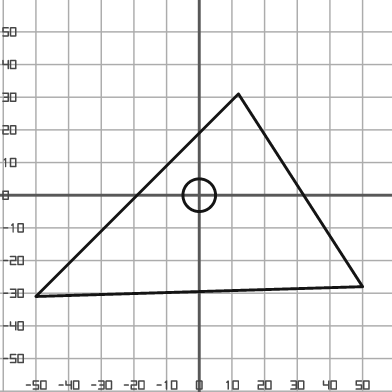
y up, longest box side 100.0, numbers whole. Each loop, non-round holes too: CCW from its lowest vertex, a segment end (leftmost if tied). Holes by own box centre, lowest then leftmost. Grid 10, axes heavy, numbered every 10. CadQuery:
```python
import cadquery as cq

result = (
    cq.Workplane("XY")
    .moveTo(-50.0, -31.0)
    .lineTo(50.0, -28.0)
    .lineTo(12.0, 31.0)
    .close()
    .moveTo(0.0, 0.0)
    .circle(5.0)
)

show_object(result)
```